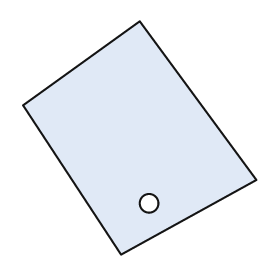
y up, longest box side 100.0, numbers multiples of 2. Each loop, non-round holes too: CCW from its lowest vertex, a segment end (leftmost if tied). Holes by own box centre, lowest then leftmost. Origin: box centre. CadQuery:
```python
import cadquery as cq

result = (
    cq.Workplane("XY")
    .moveTo(-8.0, -50.0)
    .lineTo(50.0, -18.0)
    .lineTo(0.0, 50.0)
    .lineTo(-50.0, 14.0)
    .close()
    .moveTo(4.0, -28.0)
    .circle(4.0)
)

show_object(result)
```